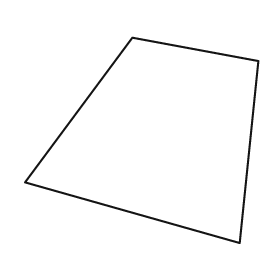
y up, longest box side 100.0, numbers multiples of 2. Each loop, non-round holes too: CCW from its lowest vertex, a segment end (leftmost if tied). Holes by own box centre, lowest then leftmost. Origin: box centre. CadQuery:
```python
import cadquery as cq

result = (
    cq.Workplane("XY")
    .moveTo(42.0, -44.0)
    .lineTo(50.0, 34.0)
    .lineTo(-4.0, 44.0)
    .lineTo(-50.0, -18.0)
    .close()
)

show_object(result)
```